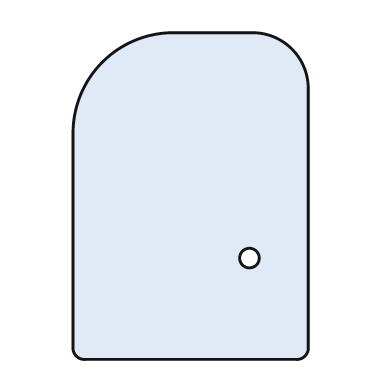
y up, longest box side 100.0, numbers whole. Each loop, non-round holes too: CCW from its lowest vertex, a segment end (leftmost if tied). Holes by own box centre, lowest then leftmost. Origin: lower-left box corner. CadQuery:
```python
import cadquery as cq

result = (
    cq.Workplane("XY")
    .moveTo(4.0, 0.0)
    .lineTo(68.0, 0.0)
    .threePointArc((71.0, 1.0), (72.0, 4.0))
    .lineTo(72.0, 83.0)
    .threePointArc((67.0, 95.0), (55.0, 100.0))
    .lineTo(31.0, 100.0)
    .threePointArc((9.0, 91.0), (0.0, 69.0))
    .lineTo(0.0, 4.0)
    .threePointArc((1.0, 1.0), (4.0, 0.0))
    .close()
    .moveTo(54.0, 31.0)
    .circle(3.0)
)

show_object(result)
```